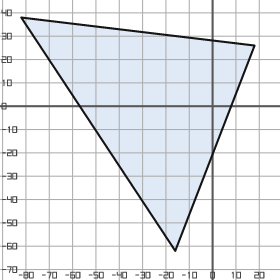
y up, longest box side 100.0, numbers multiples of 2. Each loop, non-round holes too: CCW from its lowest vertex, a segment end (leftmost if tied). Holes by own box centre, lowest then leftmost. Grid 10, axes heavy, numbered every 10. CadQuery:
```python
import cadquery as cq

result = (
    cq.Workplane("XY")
    .moveTo(-16.0, -62.0)
    .lineTo(18.0, 26.0)
    .lineTo(-82.0, 38.0)
    .close()
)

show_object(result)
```